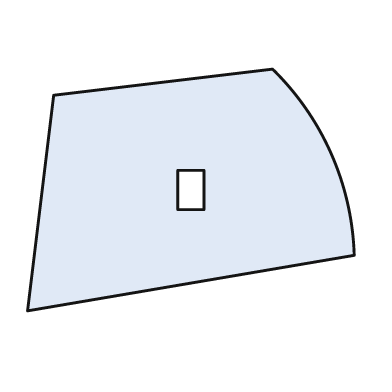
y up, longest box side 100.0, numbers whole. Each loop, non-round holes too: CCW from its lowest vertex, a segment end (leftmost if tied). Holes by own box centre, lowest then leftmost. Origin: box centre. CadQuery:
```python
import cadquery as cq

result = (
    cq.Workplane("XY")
    .moveTo(-50.0, -37.0)
    .lineTo(50.0, -20.0)
    .threePointArc((43.0, 11.0), (25.0, 37.0))
    .lineTo(-42.0, 29.0)
    .close()
    .moveTo(-4.0, -6.0)
    .lineTo(4.0, -6.0)
    .lineTo(4.0, 6.0)
    .lineTo(-4.0, 6.0)
    .close()
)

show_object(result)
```